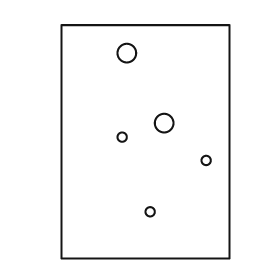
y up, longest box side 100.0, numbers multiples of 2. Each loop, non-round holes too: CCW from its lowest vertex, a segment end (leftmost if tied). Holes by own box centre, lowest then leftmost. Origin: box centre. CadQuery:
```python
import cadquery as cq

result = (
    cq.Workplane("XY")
    .moveTo(-36.0, -50.0)
    .lineTo(36.0, -50.0)
    .lineTo(36.0, 50.0)
    .lineTo(-36.0, 50.0)
    .close()
    .moveTo(2.0, -30.0)
    .circle(2.0)
    .moveTo(26.0, -8.0)
    .circle(2.0)
    .moveTo(-10.0, 2.0)
    .circle(2.0)
    .moveTo(8.0, 8.0)
    .circle(4.0)
    .moveTo(-8.0, 38.0)
    .circle(4.0)
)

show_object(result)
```